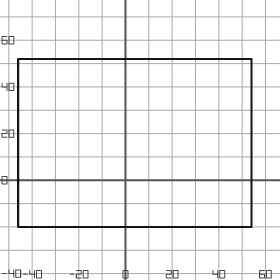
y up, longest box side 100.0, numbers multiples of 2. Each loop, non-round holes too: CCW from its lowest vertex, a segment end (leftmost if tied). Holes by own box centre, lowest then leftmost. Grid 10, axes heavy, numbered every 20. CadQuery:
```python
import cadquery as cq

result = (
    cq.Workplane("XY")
    .moveTo(-46.0, -20.0)
    .lineTo(54.0, -20.0)
    .lineTo(54.0, 52.0)
    .lineTo(-46.0, 52.0)
    .close()
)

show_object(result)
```